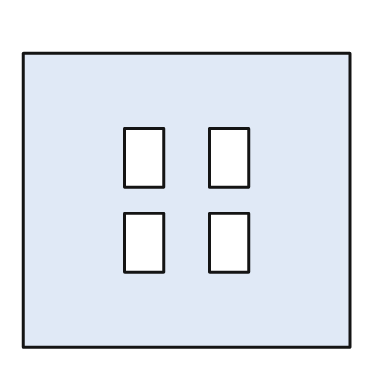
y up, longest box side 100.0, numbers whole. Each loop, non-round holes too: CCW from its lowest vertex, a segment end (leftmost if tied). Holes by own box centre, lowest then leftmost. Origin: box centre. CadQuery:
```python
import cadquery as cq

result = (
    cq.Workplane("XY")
    .moveTo(-50.0, -45.0)
    .lineTo(50.0, -45.0)
    .lineTo(50.0, 45.0)
    .lineTo(-50.0, 45.0)
    .close()
    .moveTo(-19.0, -22.0)
    .lineTo(-7.0, -22.0)
    .lineTo(-7.0, -4.0)
    .lineTo(-19.0, -4.0)
    .close()
    .moveTo(7.0, -22.0)
    .lineTo(19.0, -22.0)
    .lineTo(19.0, -4.0)
    .lineTo(7.0, -4.0)
    .close()
    .moveTo(-19.0, 4.0)
    .lineTo(-7.0, 4.0)
    .lineTo(-7.0, 22.0)
    .lineTo(-19.0, 22.0)
    .close()
    .moveTo(7.0, 4.0)
    .lineTo(19.0, 4.0)
    .lineTo(19.0, 22.0)
    .lineTo(7.0, 22.0)
    .close()
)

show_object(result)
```